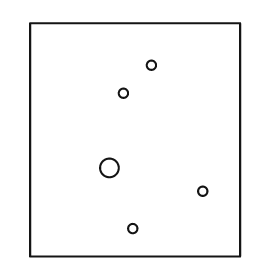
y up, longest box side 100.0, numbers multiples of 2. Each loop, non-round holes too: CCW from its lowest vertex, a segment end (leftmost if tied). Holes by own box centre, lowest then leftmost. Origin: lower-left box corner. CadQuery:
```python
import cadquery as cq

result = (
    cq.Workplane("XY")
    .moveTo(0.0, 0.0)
    .lineTo(90.0, 0.0)
    .lineTo(90.0, 100.0)
    .lineTo(0.0, 100.0)
    .close()
    .moveTo(44.0, 12.0)
    .circle(2.0)
    .moveTo(74.0, 28.0)
    .circle(2.0)
    .moveTo(34.0, 38.0)
    .circle(4.0)
    .moveTo(40.0, 70.0)
    .circle(2.0)
    .moveTo(52.0, 82.0)
    .circle(2.0)
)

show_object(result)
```